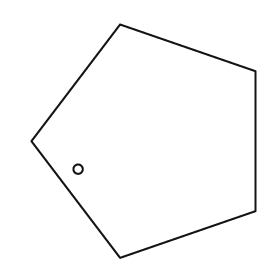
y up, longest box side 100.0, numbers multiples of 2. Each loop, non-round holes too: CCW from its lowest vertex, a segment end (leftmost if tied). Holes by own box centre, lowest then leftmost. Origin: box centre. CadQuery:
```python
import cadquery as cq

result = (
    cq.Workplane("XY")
    .moveTo(-10.0, -50.0)
    .lineTo(48.0, -30.0)
    .lineTo(48.0, 30.0)
    .lineTo(-10.0, 50.0)
    .lineTo(-48.0, 0.0)
    .close()
    .moveTo(-28.0, -12.0)
    .circle(2.0)
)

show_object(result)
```